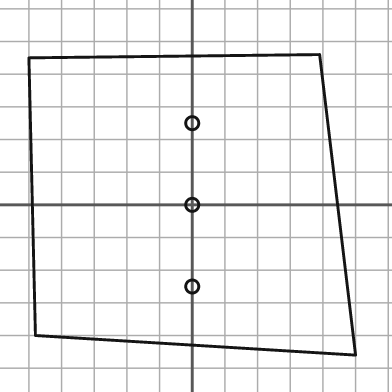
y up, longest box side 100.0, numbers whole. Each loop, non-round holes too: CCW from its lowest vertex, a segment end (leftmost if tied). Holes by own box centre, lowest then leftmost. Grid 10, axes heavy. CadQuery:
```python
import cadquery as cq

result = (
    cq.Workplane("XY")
    .moveTo(50.0, -46.0)
    .lineTo(39.0, 46.0)
    .lineTo(-50.0, 45.0)
    .lineTo(-48.0, -40.0)
    .close()
    .moveTo(0.0, -25.0)
    .circle(2.0)
    .moveTo(0.0, 0.0)
    .circle(2.0)
    .moveTo(0.0, 25.0)
    .circle(2.0)
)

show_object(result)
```